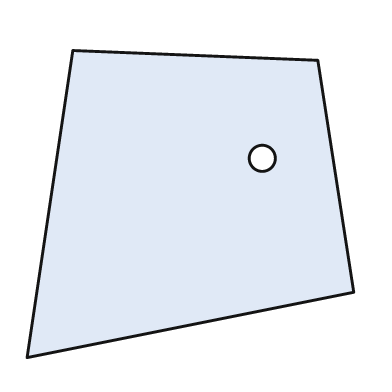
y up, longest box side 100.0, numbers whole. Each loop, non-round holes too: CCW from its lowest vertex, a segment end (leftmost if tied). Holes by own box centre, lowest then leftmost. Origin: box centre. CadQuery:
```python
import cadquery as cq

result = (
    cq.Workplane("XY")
    .moveTo(-50.0, -47.0)
    .lineTo(50.0, -27.0)
    .lineTo(39.0, 44.0)
    .lineTo(-36.0, 47.0)
    .close()
    .moveTo(22.0, 14.0)
    .circle(4.0)
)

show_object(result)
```